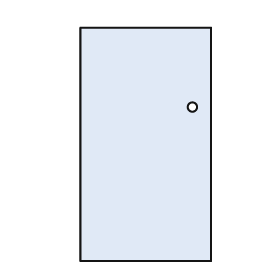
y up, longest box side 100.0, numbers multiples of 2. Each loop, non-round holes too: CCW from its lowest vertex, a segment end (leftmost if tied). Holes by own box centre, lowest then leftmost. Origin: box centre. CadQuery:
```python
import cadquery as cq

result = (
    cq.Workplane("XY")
    .moveTo(-28.0, -50.0)
    .lineTo(28.0, -50.0)
    .lineTo(28.0, 50.0)
    .lineTo(-28.0, 50.0)
    .close()
    .moveTo(20.0, 16.0)
    .circle(2.0)
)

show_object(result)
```